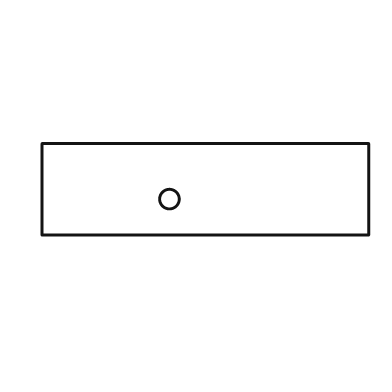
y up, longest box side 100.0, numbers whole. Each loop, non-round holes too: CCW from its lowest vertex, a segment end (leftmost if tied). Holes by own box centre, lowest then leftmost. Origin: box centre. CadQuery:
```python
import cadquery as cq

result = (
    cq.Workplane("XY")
    .moveTo(-50.0, -14.0)
    .lineTo(50.0, -14.0)
    .lineTo(50.0, 14.0)
    .lineTo(-50.0, 14.0)
    .close()
    .moveTo(-11.0, -3.0)
    .circle(3.0)
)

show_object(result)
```